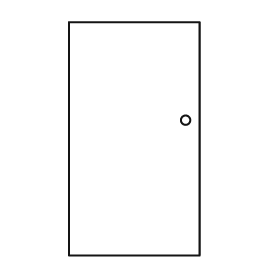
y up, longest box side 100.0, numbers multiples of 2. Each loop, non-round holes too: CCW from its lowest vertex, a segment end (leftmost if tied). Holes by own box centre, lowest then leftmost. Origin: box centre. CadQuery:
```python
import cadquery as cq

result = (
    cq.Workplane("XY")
    .moveTo(-28.0, -50.0)
    .lineTo(28.0, -50.0)
    .lineTo(28.0, 50.0)
    .lineTo(-28.0, 50.0)
    .close()
    .moveTo(22.0, 8.0)
    .circle(2.0)
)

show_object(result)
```